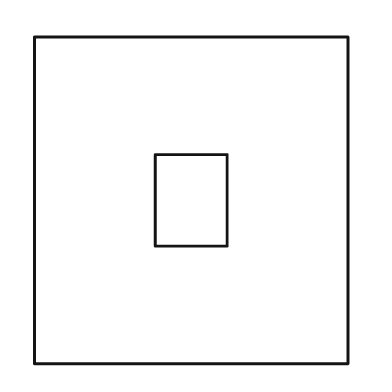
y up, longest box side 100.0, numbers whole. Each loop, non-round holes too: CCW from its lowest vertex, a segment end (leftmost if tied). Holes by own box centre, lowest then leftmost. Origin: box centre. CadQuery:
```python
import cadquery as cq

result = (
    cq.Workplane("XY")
    .moveTo(-48.0, -50.0)
    .lineTo(48.0, -50.0)
    .lineTo(48.0, 50.0)
    .lineTo(-48.0, 50.0)
    .close()
    .moveTo(-11.0, -14.0)
    .lineTo(11.0, -14.0)
    .lineTo(11.0, 14.0)
    .lineTo(-11.0, 14.0)
    .close()
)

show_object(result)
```